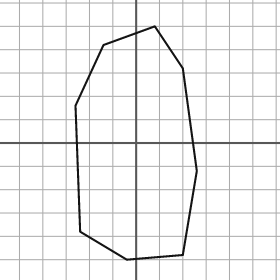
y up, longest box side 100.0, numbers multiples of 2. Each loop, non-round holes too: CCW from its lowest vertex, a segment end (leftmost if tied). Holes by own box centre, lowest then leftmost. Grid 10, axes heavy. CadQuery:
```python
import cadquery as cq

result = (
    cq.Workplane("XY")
    .moveTo(-4.0, -50.0)
    .lineTo(20.0, -48.0)
    .lineTo(26.0, -12.0)
    .lineTo(20.0, 32.0)
    .lineTo(8.0, 50.0)
    .lineTo(-14.0, 42.0)
    .lineTo(-26.0, 16.0)
    .lineTo(-24.0, -38.0)
    .close()
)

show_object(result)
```